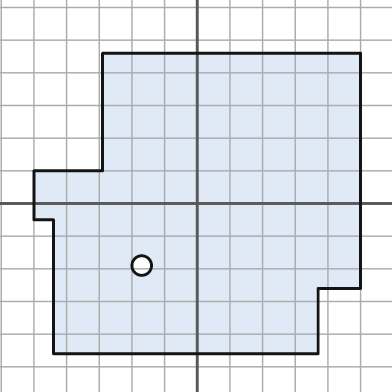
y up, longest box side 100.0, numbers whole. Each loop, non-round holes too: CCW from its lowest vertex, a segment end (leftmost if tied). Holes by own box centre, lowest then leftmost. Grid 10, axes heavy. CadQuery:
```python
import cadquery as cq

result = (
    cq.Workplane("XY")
    .moveTo(-44.0, -46.0)
    .lineTo(37.0, -46.0)
    .lineTo(37.0, -26.0)
    .lineTo(50.0, -26.0)
    .lineTo(50.0, 46.0)
    .lineTo(-29.0, 46.0)
    .lineTo(-29.0, 10.0)
    .lineTo(-50.0, 10.0)
    .lineTo(-50.0, -5.0)
    .lineTo(-44.0, -5.0)
    .close()
    .moveTo(-17.0, -19.0)
    .circle(3.0)
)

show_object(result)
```